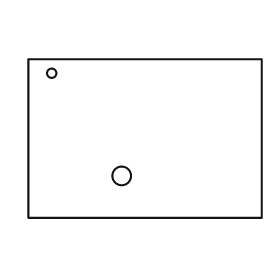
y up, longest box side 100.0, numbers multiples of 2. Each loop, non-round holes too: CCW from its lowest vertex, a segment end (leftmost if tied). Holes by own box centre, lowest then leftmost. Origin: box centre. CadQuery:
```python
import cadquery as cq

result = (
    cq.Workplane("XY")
    .moveTo(-50.0, -34.0)
    .lineTo(50.0, -34.0)
    .lineTo(50.0, 34.0)
    .lineTo(-50.0, 34.0)
    .close()
    .moveTo(-10.0, -16.0)
    .circle(4.0)
    .moveTo(-40.0, 28.0)
    .circle(2.0)
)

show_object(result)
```